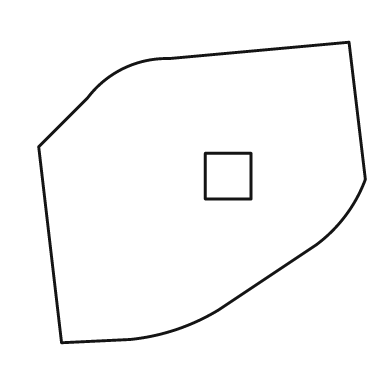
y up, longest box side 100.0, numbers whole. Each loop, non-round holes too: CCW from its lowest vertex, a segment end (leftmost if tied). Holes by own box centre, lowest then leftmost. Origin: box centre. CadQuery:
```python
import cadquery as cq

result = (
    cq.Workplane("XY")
    .moveTo(-43.0, -46.0)
    .lineTo(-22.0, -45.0)
    .threePointArc((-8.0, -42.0), (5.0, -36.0))
    .lineTo(35.0, -16.0)
    .threePointArc((44.0, -7.0), (50.0, 4.0))
    .lineTo(45.0, 46.0)
    .lineTo(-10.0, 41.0)
    .threePointArc((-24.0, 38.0), (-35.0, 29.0))
    .lineTo(-50.0, 14.0)
    .close()
    .moveTo(1.0, -2.0)
    .lineTo(15.0, -2.0)
    .lineTo(15.0, 12.0)
    .lineTo(1.0, 12.0)
    .close()
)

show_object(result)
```